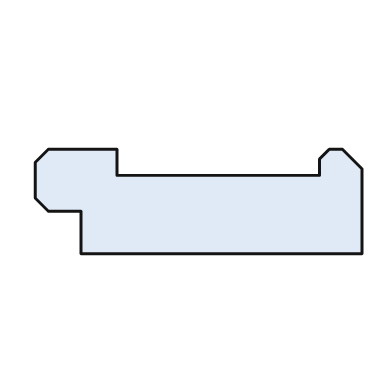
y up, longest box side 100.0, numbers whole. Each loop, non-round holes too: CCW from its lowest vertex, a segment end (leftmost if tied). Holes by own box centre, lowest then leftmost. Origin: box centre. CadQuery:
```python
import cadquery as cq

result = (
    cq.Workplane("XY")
    .moveTo(-36.0, -16.0)
    .lineTo(50.0, -16.0)
    .lineTo(50.0, 10.0)
    .lineTo(44.0, 16.0)
    .lineTo(40.0, 16.0)
    .lineTo(37.0, 13.0)
    .lineTo(37.0, 8.0)
    .lineTo(-25.0, 8.0)
    .lineTo(-25.0, 16.0)
    .lineTo(-46.0, 16.0)
    .lineTo(-50.0, 12.0)
    .lineTo(-50.0, 1.0)
    .lineTo(-46.0, -3.0)
    .lineTo(-36.0, -3.0)
    .close()
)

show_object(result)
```